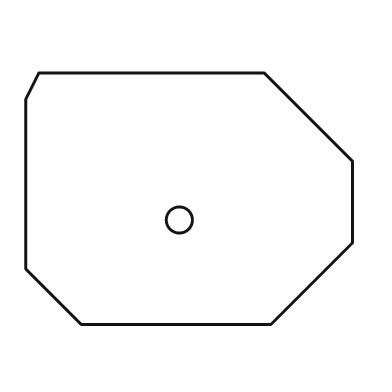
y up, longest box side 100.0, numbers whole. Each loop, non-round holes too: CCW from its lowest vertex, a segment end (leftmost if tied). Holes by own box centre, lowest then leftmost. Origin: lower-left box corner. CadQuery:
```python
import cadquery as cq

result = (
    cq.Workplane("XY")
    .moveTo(17.0, 0.0)
    .lineTo(75.0, 0.0)
    .lineTo(100.0, 25.0)
    .lineTo(100.0, 50.0)
    .lineTo(73.0, 77.0)
    .lineTo(4.0, 77.0)
    .lineTo(0.0, 69.0)
    .lineTo(0.0, 17.0)
    .close()
    .moveTo(47.0, 32.0)
    .circle(4.0)
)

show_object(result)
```